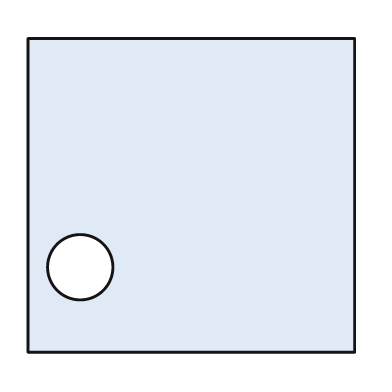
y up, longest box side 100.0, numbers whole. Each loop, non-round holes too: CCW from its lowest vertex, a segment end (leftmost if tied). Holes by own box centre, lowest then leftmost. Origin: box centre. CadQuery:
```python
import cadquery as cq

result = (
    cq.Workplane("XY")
    .moveTo(-50.0, -48.0)
    .lineTo(50.0, -48.0)
    .lineTo(50.0, 48.0)
    .lineTo(-50.0, 48.0)
    .close()
    .moveTo(-34.0, -22.0)
    .circle(10.0)
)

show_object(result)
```